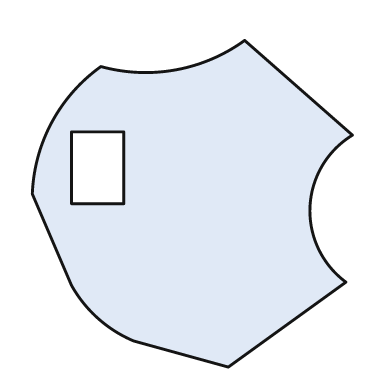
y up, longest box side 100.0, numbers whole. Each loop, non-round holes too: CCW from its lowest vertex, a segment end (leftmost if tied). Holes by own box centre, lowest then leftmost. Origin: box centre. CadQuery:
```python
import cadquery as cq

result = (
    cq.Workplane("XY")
    .moveTo(11.0, -50.0)
    .lineTo(47.0, -24.0)
    .threePointArc((36.0, -1.0), (49.0, 21.0))
    .lineTo(16.0, 50.0)
    .threePointArc((-5.0, 41.0), (-28.0, 42.0))
    .threePointArc((-43.0, 25.0), (-49.0, 3.0))
    .lineTo(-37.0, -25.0)
    .threePointArc((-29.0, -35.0), (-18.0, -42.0))
    .close()
    .moveTo(-37.0, 0.0)
    .lineTo(-21.0, 0.0)
    .lineTo(-21.0, 22.0)
    .lineTo(-37.0, 22.0)
    .close()
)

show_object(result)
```